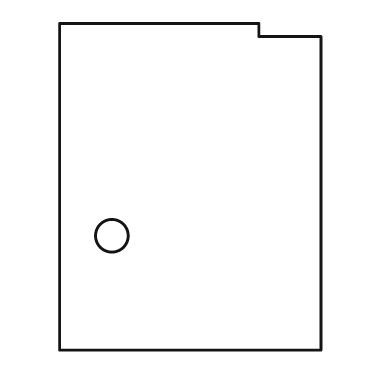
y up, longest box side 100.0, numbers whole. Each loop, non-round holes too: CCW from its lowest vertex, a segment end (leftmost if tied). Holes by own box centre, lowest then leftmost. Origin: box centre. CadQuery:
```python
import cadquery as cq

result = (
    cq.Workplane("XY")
    .moveTo(-40.0, -50.0)
    .lineTo(40.0, -50.0)
    .lineTo(40.0, 46.0)
    .lineTo(21.0, 46.0)
    .lineTo(21.0, 50.0)
    .lineTo(-40.0, 50.0)
    .close()
    .moveTo(-24.0, -15.0)
    .circle(5.0)
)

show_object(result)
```